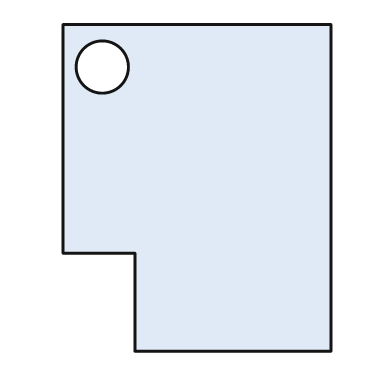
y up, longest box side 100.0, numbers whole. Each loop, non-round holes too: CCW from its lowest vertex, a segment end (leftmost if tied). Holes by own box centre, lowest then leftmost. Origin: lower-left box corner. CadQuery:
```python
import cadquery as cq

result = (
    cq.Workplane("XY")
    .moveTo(22.0, 0.0)
    .lineTo(82.0, 0.0)
    .lineTo(82.0, 100.0)
    .lineTo(0.0, 100.0)
    .lineTo(0.0, 30.0)
    .lineTo(22.0, 30.0)
    .close()
    .moveTo(12.0, 87.0)
    .circle(8.0)
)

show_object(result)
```